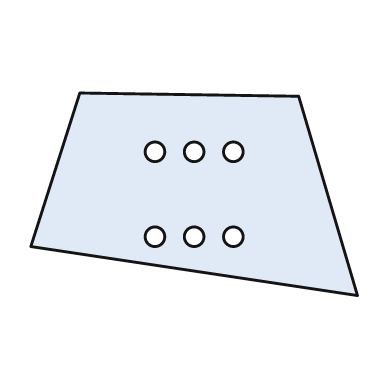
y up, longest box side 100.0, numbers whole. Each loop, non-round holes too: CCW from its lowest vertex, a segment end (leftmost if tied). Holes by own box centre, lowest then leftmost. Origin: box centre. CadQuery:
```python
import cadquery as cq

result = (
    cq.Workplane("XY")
    .moveTo(50.0, -31.0)
    .lineTo(32.0, 30.0)
    .lineTo(-35.0, 31.0)
    .lineTo(-50.0, -16.0)
    .close()
    .moveTo(-12.0, -13.0)
    .circle(3.0)
    .moveTo(0.0, -13.0)
    .circle(3.0)
    .moveTo(12.0, -13.0)
    .circle(3.0)
    .moveTo(-12.0, 13.0)
    .circle(3.0)
    .moveTo(0.0, 13.0)
    .circle(3.0)
    .moveTo(12.0, 13.0)
    .circle(3.0)
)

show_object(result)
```